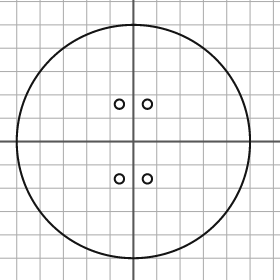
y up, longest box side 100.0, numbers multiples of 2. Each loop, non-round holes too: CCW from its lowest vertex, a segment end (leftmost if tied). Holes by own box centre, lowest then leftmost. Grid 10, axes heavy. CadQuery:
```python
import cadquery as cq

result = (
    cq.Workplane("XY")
    .moveTo(0.0, 0.0)
    .circle(50.0)
    .moveTo(-6.0, -16.0)
    .circle(2.0)
    .moveTo(6.0, -16.0)
    .circle(2.0)
    .moveTo(-6.0, 16.0)
    .circle(2.0)
    .moveTo(6.0, 16.0)
    .circle(2.0)
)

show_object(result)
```